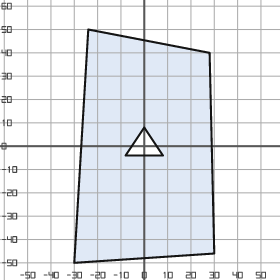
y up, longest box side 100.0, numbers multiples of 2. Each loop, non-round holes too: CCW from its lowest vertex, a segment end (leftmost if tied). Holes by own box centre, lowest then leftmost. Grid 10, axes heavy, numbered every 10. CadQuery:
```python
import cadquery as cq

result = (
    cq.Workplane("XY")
    .moveTo(-30.0, -50.0)
    .lineTo(30.0, -46.0)
    .lineTo(28.0, 40.0)
    .lineTo(-24.0, 50.0)
    .close()
    .moveTo(-8.0, -4.0)
    .lineTo(8.0, -4.0)
    .lineTo(0.0, 8.0)
    .close()
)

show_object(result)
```